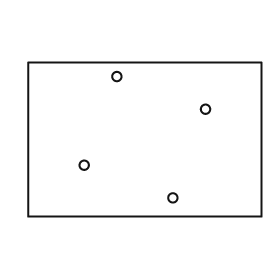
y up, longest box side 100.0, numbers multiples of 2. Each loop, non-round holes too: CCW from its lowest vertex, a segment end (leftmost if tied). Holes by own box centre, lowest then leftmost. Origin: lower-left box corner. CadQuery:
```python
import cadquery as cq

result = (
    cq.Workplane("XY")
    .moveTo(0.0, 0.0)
    .lineTo(100.0, 0.0)
    .lineTo(100.0, 66.0)
    .lineTo(0.0, 66.0)
    .close()
    .moveTo(62.0, 8.0)
    .circle(2.0)
    .moveTo(24.0, 22.0)
    .circle(2.0)
    .moveTo(76.0, 46.0)
    .circle(2.0)
    .moveTo(38.0, 60.0)
    .circle(2.0)
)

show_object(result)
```